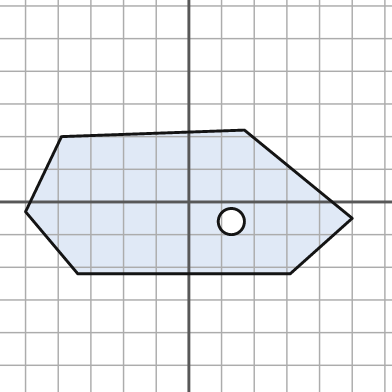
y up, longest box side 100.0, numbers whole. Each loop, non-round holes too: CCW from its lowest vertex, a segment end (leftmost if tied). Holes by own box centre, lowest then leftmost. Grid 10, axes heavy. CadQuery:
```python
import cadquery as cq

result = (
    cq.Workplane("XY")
    .moveTo(-34.0, -22.0)
    .lineTo(31.0, -22.0)
    .lineTo(50.0, -5.0)
    .lineTo(17.0, 22.0)
    .lineTo(-39.0, 20.0)
    .lineTo(-50.0, -3.0)
    .close()
    .moveTo(13.0, -6.0)
    .circle(4.0)
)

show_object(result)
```